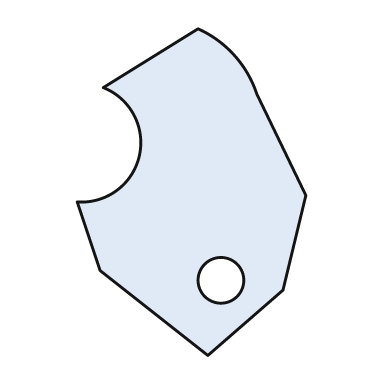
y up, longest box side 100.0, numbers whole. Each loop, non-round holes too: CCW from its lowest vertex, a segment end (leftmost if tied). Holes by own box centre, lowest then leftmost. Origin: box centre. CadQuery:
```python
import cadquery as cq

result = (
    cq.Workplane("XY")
    .moveTo(5.0, -50.0)
    .lineTo(28.0, -30.0)
    .lineTo(35.0, -1.0)
    .lineTo(20.0, 30.0)
    .threePointArc((13.0, 42.0), (2.0, 50.0))
    .lineTo(-27.0, 32.0)
    .threePointArc((-16.0, 11.0), (-35.0, -3.0))
    .lineTo(-28.0, -24.0)
    .close()
    .moveTo(9.0, -27.0)
    .circle(7.0)
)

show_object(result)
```